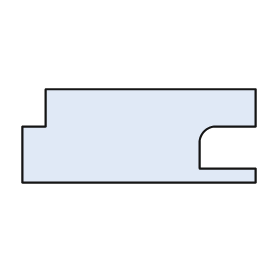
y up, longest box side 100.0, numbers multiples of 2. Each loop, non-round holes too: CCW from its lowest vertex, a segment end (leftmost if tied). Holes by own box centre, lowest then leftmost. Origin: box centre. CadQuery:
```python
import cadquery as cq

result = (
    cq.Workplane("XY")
    .moveTo(-50.0, -20.0)
    .lineTo(50.0, -20.0)
    .lineTo(50.0, -14.0)
    .lineTo(26.0, -14.0)
    .lineTo(26.0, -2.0)
    .threePointArc((28.0, 2.0), (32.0, 4.0))
    .lineTo(50.0, 4.0)
    .lineTo(50.0, 20.0)
    .lineTo(-40.0, 20.0)
    .lineTo(-40.0, 4.0)
    .lineTo(-50.0, 4.0)
    .close()
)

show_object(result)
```